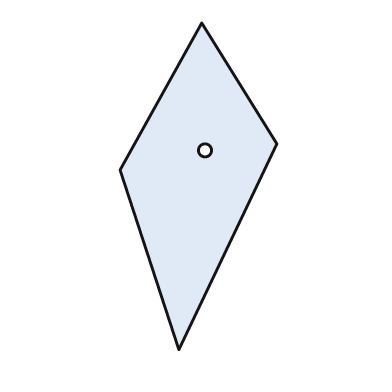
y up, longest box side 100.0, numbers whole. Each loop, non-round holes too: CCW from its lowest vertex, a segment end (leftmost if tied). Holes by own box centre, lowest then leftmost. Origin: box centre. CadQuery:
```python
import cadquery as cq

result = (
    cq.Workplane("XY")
    .moveTo(-6.0, -50.0)
    .lineTo(24.0, 13.0)
    .lineTo(1.0, 50.0)
    .lineTo(-24.0, 5.0)
    .close()
    .moveTo(2.0, 11.0)
    .circle(2.0)
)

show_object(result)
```